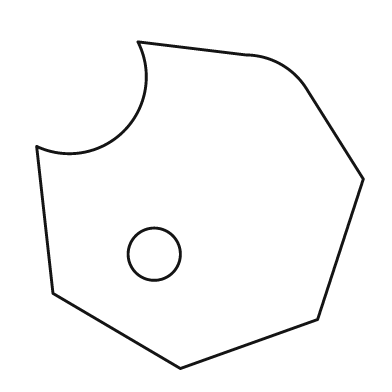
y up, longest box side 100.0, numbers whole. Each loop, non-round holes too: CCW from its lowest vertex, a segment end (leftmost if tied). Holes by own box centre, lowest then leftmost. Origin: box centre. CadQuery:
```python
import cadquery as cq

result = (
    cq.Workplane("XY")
    .moveTo(-6.0, -50.0)
    .lineTo(36.0, -35.0)
    .lineTo(50.0, 8.0)
    .lineTo(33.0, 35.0)
    .threePointArc((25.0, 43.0), (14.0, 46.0))
    .lineTo(-19.0, 50.0)
    .threePointArc((-23.0, 23.0), (-50.0, 18.0))
    .lineTo(-45.0, -27.0)
    .close()
    .moveTo(-14.0, -15.0)
    .circle(8.0)
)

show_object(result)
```